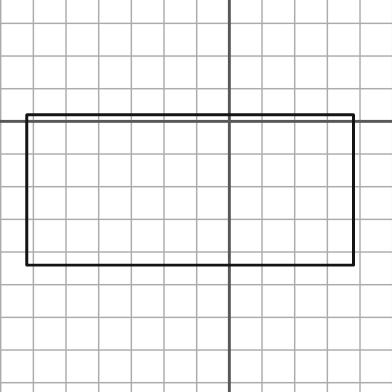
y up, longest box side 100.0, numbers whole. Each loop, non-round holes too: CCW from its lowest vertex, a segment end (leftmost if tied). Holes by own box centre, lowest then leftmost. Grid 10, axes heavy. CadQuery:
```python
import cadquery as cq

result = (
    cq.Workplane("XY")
    .moveTo(-62.0, -44.0)
    .lineTo(38.0, -44.0)
    .lineTo(38.0, 2.0)
    .lineTo(-62.0, 2.0)
    .close()
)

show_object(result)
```